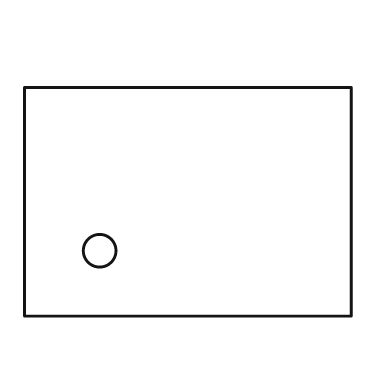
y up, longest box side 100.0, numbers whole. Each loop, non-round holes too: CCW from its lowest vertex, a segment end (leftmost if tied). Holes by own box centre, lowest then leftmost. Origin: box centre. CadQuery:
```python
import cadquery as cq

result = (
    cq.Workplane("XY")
    .moveTo(-50.0, -35.0)
    .lineTo(50.0, -35.0)
    .lineTo(50.0, 35.0)
    .lineTo(-50.0, 35.0)
    .close()
    .moveTo(-27.0, -15.0)
    .circle(5.0)
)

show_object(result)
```